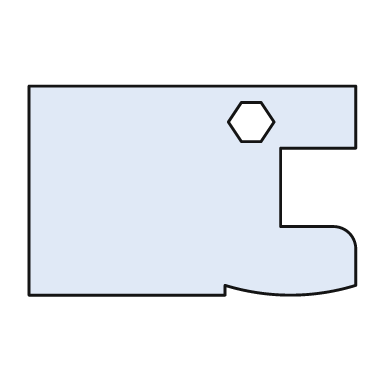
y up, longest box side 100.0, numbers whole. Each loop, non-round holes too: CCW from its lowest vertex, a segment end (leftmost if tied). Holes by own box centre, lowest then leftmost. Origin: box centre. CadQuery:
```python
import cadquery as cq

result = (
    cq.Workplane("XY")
    .moveTo(-50.0, -32.0)
    .lineTo(10.0, -32.0)
    .lineTo(10.0, -29.0)
    .threePointArc((30.0, -32.0), (50.0, -29.0))
    .lineTo(50.0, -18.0)
    .threePointArc((48.0, -13.0), (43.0, -11.0))
    .lineTo(27.0, -11.0)
    .lineTo(27.0, 13.0)
    .lineTo(50.0, 13.0)
    .lineTo(50.0, 32.0)
    .lineTo(-50.0, 32.0)
    .close()
    .moveTo(15.0, 15.0)
    .lineTo(21.0, 15.0)
    .lineTo(25.0, 21.0)
    .lineTo(21.0, 27.0)
    .lineTo(15.0, 27.0)
    .lineTo(11.0, 21.0)
    .close()
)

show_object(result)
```